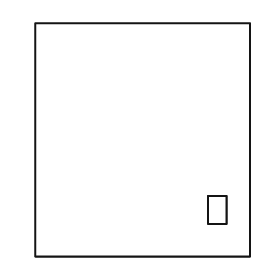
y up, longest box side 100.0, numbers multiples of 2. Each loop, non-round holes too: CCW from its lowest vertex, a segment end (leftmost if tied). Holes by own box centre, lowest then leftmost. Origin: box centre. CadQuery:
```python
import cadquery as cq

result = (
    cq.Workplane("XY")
    .moveTo(-46.0, -50.0)
    .lineTo(46.0, -50.0)
    .lineTo(46.0, 50.0)
    .lineTo(-46.0, 50.0)
    .close()
    .moveTo(28.0, -36.0)
    .lineTo(36.0, -36.0)
    .lineTo(36.0, -24.0)
    .lineTo(28.0, -24.0)
    .close()
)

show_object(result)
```